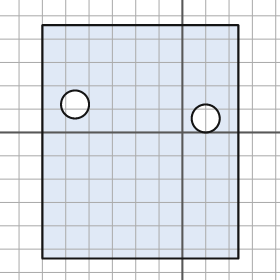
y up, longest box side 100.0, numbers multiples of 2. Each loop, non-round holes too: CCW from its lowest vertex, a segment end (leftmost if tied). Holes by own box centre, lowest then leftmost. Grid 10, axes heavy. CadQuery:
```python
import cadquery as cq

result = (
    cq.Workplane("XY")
    .moveTo(-60.0, -54.0)
    .lineTo(24.0, -54.0)
    .lineTo(24.0, 46.0)
    .lineTo(-60.0, 46.0)
    .close()
    .moveTo(10.0, 6.0)
    .circle(6.0)
    .moveTo(-46.0, 12.0)
    .circle(6.0)
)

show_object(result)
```